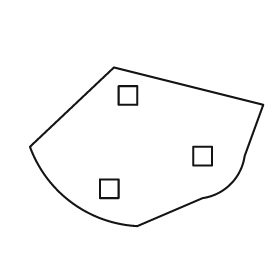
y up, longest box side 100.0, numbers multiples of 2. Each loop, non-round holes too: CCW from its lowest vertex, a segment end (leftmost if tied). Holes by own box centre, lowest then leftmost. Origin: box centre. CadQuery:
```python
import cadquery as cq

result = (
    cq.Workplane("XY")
    .moveTo(-4.0, -34.0)
    .lineTo(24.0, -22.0)
    .threePointArc((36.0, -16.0), (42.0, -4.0))
    .lineTo(50.0, 18.0)
    .lineTo(-14.0, 34.0)
    .lineTo(-50.0, 0.0)
    .threePointArc((-32.0, -24.0), (-4.0, -34.0))
    .close()
    .moveTo(-20.0, -22.0)
    .lineTo(-12.0, -22.0)
    .lineTo(-12.0, -14.0)
    .lineTo(-20.0, -14.0)
    .close()
    .moveTo(20.0, -8.0)
    .lineTo(28.0, -8.0)
    .lineTo(28.0, 0.0)
    .lineTo(20.0, 0.0)
    .close()
    .moveTo(-12.0, 18.0)
    .lineTo(-4.0, 18.0)
    .lineTo(-4.0, 26.0)
    .lineTo(-12.0, 26.0)
    .close()
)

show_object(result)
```